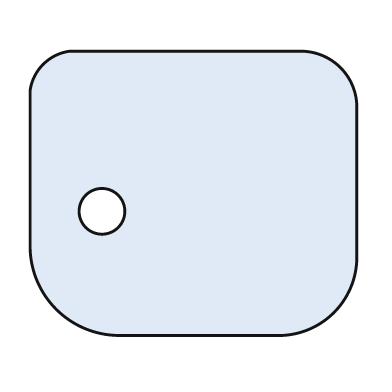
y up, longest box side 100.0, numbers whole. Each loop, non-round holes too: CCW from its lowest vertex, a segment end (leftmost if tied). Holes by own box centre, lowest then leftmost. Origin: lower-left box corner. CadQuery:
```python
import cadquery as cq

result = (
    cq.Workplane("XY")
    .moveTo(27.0, 0.0)
    .lineTo(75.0, 0.0)
    .threePointArc((93.0, 7.0), (100.0, 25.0))
    .lineTo(100.0, 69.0)
    .threePointArc((95.0, 82.0), (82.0, 87.0))
    .lineTo(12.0, 87.0)
    .threePointArc((4.0, 83.0), (0.0, 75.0))
    .lineTo(0.0, 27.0)
    .threePointArc((8.0, 8.0), (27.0, 0.0))
    .close()
    .moveTo(22.0, 38.0)
    .circle(7.0)
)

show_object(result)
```